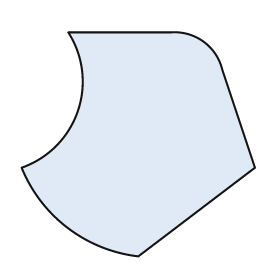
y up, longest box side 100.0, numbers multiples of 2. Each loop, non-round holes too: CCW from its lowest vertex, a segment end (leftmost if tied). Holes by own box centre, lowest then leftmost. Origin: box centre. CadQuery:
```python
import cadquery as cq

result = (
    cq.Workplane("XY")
    .moveTo(0.0, -48.0)
    .lineTo(50.0, -10.0)
    .lineTo(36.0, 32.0)
    .threePointArc((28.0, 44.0), (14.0, 48.0))
    .lineTo(-30.0, 48.0)
    .threePointArc((-26.0, 14.0), (-50.0, -10.0))
    .threePointArc((-30.0, -36.0), (0.0, -48.0))
    .close()
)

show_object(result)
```